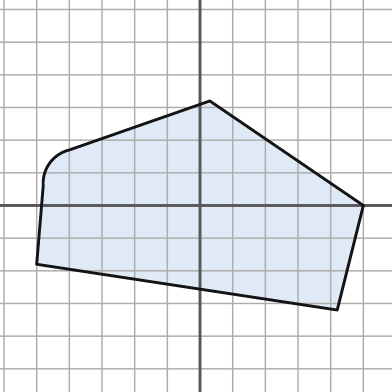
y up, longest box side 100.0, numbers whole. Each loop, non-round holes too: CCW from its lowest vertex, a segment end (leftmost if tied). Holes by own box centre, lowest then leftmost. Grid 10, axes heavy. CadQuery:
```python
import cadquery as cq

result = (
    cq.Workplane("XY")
    .moveTo(42.0, -32.0)
    .lineTo(50.0, 0.0)
    .lineTo(3.0, 32.0)
    .lineTo(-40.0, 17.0)
    .threePointArc((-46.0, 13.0), (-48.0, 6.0))
    .lineTo(-50.0, -18.0)
    .close()
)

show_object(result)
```